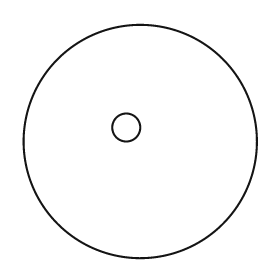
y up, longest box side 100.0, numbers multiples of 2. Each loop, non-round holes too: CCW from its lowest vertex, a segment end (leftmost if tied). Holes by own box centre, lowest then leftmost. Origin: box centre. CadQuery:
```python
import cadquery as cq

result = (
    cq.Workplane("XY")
    .moveTo(0.0, 0.0)
    .circle(50.0)
    .moveTo(-6.0, 6.0)
    .circle(6.0)
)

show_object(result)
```